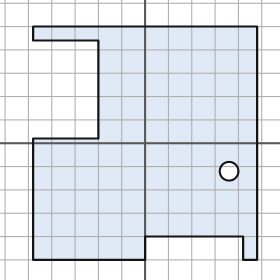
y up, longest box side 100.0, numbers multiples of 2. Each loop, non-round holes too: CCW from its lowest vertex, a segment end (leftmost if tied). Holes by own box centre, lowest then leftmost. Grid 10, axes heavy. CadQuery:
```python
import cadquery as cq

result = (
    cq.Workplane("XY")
    .moveTo(-48.0, -50.0)
    .lineTo(0.0, -50.0)
    .lineTo(0.0, -40.0)
    .lineTo(42.0, -40.0)
    .lineTo(42.0, -50.0)
    .lineTo(48.0, -50.0)
    .lineTo(48.0, 50.0)
    .lineTo(-48.0, 50.0)
    .lineTo(-48.0, 44.0)
    .lineTo(-20.0, 44.0)
    .lineTo(-20.0, 2.0)
    .lineTo(-48.0, 2.0)
    .close()
    .moveTo(36.0, -12.0)
    .circle(4.0)
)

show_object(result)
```